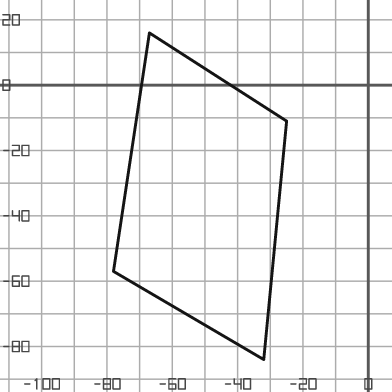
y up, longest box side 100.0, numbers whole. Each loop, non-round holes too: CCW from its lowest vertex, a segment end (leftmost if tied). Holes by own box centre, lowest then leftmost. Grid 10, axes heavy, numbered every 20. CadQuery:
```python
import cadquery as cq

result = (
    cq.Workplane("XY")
    .moveTo(-32.0, -84.0)
    .lineTo(-25.0, -11.0)
    .lineTo(-67.0, 16.0)
    .lineTo(-78.0, -57.0)
    .close()
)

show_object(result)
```